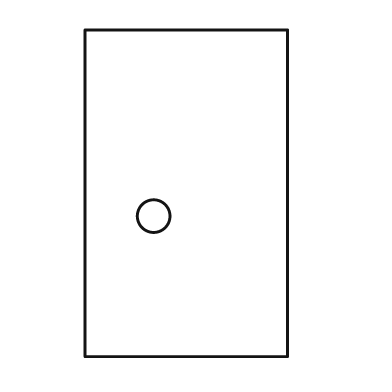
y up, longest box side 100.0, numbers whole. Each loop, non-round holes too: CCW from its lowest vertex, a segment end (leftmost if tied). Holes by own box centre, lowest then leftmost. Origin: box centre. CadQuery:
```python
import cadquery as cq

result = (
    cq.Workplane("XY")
    .moveTo(-31.0, -50.0)
    .lineTo(31.0, -50.0)
    .lineTo(31.0, 50.0)
    .lineTo(-31.0, 50.0)
    .close()
    .moveTo(-10.0, -7.0)
    .circle(5.0)
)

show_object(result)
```